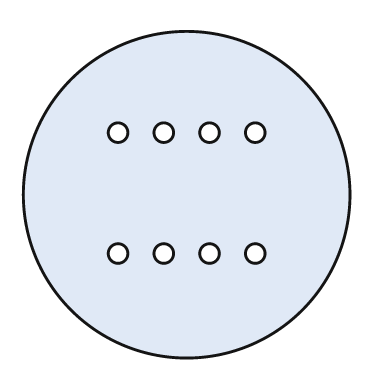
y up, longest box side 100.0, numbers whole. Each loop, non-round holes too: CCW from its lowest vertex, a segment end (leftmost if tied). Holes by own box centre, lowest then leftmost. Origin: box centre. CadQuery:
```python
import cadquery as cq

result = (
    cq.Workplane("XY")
    .moveTo(0.0, 0.0)
    .circle(50.0)
    .moveTo(-21.0, -18.0)
    .circle(3.0)
    .moveTo(-7.0, -18.0)
    .circle(3.0)
    .moveTo(7.0, -18.0)
    .circle(3.0)
    .moveTo(21.0, -18.0)
    .circle(3.0)
    .moveTo(-21.0, 19.0)
    .circle(3.0)
    .moveTo(-7.0, 19.0)
    .circle(3.0)
    .moveTo(7.0, 19.0)
    .circle(3.0)
    .moveTo(21.0, 19.0)
    .circle(3.0)
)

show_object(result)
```